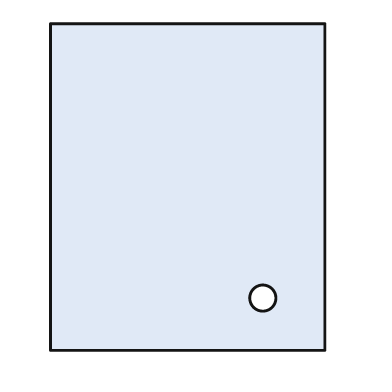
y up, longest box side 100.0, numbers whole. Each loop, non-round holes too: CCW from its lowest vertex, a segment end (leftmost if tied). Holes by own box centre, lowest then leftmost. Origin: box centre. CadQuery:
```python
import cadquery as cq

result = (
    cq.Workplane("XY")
    .moveTo(-42.0, -50.0)
    .lineTo(42.0, -50.0)
    .lineTo(42.0, 50.0)
    .lineTo(-42.0, 50.0)
    .close()
    .moveTo(23.0, -34.0)
    .circle(4.0)
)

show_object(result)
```